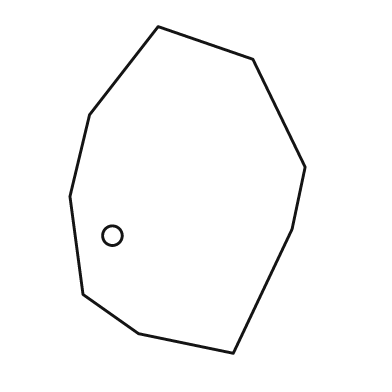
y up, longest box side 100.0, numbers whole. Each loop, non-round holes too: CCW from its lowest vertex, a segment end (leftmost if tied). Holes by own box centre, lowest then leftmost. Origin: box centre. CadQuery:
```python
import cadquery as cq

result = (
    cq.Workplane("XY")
    .moveTo(14.0, -50.0)
    .lineTo(32.0, -12.0)
    .lineTo(36.0, 7.0)
    .lineTo(20.0, 40.0)
    .lineTo(-9.0, 50.0)
    .lineTo(-30.0, 23.0)
    .lineTo(-36.0, -2.0)
    .lineTo(-32.0, -32.0)
    .lineTo(-15.0, -44.0)
    .close()
    .moveTo(-23.0, -14.0)
    .circle(3.0)
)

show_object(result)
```